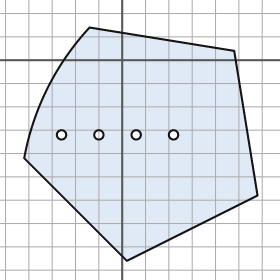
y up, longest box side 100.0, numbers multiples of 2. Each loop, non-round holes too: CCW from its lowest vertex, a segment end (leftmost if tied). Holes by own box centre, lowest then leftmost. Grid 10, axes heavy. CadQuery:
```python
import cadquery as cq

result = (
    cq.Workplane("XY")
    .moveTo(2.0, -86.0)
    .lineTo(58.0, -58.0)
    .lineTo(48.0, 4.0)
    .lineTo(-14.0, 14.0)
    .threePointArc((-32.0, -12.0), (-42.0, -42.0))
    .close()
    .moveTo(-26.0, -32.0)
    .circle(2.0)
    .moveTo(-10.0, -32.0)
    .circle(2.0)
    .moveTo(6.0, -32.0)
    .circle(2.0)
    .moveTo(22.0, -32.0)
    .circle(2.0)
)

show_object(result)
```